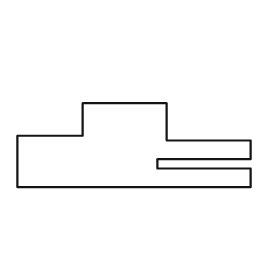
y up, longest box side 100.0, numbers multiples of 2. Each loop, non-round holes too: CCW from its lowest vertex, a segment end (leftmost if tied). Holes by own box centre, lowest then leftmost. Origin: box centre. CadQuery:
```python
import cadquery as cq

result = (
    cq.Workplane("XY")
    .moveTo(-50.0, -18.0)
    .lineTo(50.0, -18.0)
    .lineTo(50.0, -10.0)
    .lineTo(10.0, -10.0)
    .lineTo(10.0, -6.0)
    .lineTo(50.0, -6.0)
    .lineTo(50.0, 2.0)
    .lineTo(14.0, 2.0)
    .lineTo(14.0, 18.0)
    .lineTo(-22.0, 18.0)
    .lineTo(-22.0, 4.0)
    .lineTo(-50.0, 4.0)
    .close()
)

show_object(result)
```